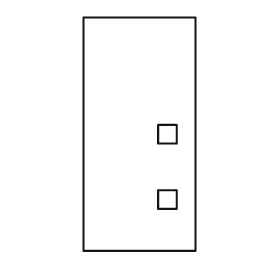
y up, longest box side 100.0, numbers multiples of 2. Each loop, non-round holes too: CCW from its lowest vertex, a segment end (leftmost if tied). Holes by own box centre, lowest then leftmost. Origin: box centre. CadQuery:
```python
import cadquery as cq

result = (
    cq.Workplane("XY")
    .moveTo(-24.0, -50.0)
    .lineTo(24.0, -50.0)
    .lineTo(24.0, 50.0)
    .lineTo(-24.0, 50.0)
    .close()
    .moveTo(8.0, -32.0)
    .lineTo(16.0, -32.0)
    .lineTo(16.0, -24.0)
    .lineTo(8.0, -24.0)
    .close()
    .moveTo(8.0, -4.0)
    .lineTo(16.0, -4.0)
    .lineTo(16.0, 4.0)
    .lineTo(8.0, 4.0)
    .close()
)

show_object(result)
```